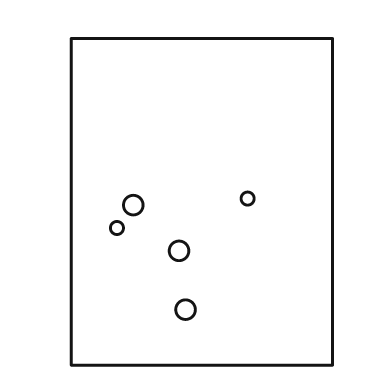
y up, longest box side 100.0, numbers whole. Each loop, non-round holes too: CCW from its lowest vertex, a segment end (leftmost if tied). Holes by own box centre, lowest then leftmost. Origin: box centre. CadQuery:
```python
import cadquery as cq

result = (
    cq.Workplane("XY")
    .moveTo(-40.0, -50.0)
    .lineTo(40.0, -50.0)
    .lineTo(40.0, 50.0)
    .lineTo(-40.0, 50.0)
    .close()
    .moveTo(-5.0, -33.0)
    .circle(3.0)
    .moveTo(-7.0, -15.0)
    .circle(3.0)
    .moveTo(-26.0, -8.0)
    .circle(2.0)
    .moveTo(-21.0, -1.0)
    .circle(3.0)
    .moveTo(14.0, 1.0)
    .circle(2.0)
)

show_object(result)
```